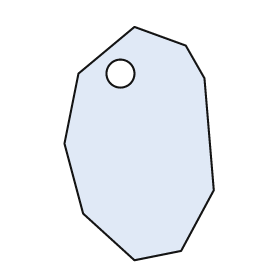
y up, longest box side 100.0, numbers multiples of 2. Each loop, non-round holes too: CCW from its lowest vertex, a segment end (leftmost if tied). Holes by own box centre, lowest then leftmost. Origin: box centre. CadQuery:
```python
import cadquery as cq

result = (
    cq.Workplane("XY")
    .moveTo(-2.0, -50.0)
    .lineTo(18.0, -46.0)
    .lineTo(32.0, -20.0)
    .lineTo(28.0, 28.0)
    .lineTo(20.0, 42.0)
    .lineTo(-2.0, 50.0)
    .lineTo(-26.0, 30.0)
    .lineTo(-32.0, 0.0)
    .lineTo(-24.0, -30.0)
    .close()
    .moveTo(-8.0, 30.0)
    .circle(6.0)
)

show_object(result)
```